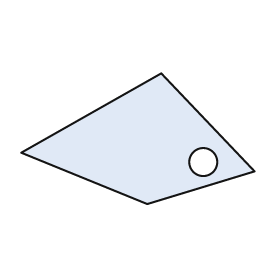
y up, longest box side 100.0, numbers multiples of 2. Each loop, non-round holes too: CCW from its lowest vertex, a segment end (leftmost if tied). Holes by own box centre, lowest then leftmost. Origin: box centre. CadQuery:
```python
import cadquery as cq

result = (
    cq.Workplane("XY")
    .moveTo(4.0, -28.0)
    .lineTo(50.0, -14.0)
    .lineTo(10.0, 28.0)
    .lineTo(-50.0, -6.0)
    .close()
    .moveTo(28.0, -10.0)
    .circle(6.0)
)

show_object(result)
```